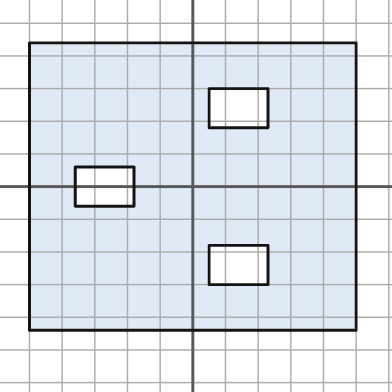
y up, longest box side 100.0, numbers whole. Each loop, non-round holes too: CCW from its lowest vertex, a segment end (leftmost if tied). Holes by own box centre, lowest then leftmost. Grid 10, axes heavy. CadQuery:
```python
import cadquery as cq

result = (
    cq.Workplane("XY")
    .moveTo(-50.0, -44.0)
    .lineTo(50.0, -44.0)
    .lineTo(50.0, 44.0)
    .lineTo(-50.0, 44.0)
    .close()
    .moveTo(5.0, -30.0)
    .lineTo(23.0, -30.0)
    .lineTo(23.0, -18.0)
    .lineTo(5.0, -18.0)
    .close()
    .moveTo(-36.0, -6.0)
    .lineTo(-18.0, -6.0)
    .lineTo(-18.0, 6.0)
    .lineTo(-36.0, 6.0)
    .close()
    .moveTo(5.0, 18.0)
    .lineTo(23.0, 18.0)
    .lineTo(23.0, 30.0)
    .lineTo(5.0, 30.0)
    .close()
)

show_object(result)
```